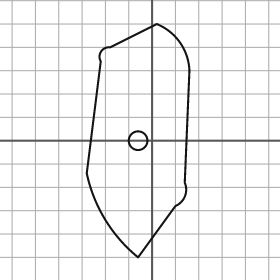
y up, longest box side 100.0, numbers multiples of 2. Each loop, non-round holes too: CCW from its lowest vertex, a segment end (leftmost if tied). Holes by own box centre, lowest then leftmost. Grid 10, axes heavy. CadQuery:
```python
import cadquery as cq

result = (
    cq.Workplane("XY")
    .moveTo(-6.0, -50.0)
    .lineTo(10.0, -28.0)
    .threePointArc((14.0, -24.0), (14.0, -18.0))
    .lineTo(16.0, 30.0)
    .threePointArc((12.0, 42.0), (2.0, 50.0))
    .lineTo(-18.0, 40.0)
    .threePointArc((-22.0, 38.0), (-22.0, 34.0))
    .lineTo(-28.0, -14.0)
    .threePointArc((-20.0, -34.0), (-6.0, -50.0))
    .close()
    .moveTo(-6.0, 0.0)
    .circle(4.0)
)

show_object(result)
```